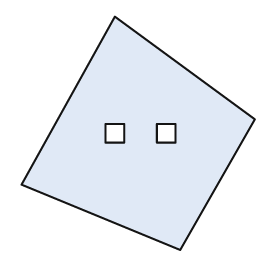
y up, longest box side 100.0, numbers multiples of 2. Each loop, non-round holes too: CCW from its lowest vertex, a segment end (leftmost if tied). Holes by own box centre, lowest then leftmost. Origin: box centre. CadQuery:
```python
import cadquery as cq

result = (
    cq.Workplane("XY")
    .moveTo(18.0, -50.0)
    .lineTo(50.0, 6.0)
    .lineTo(-10.0, 50.0)
    .lineTo(-50.0, -22.0)
    .close()
    .moveTo(-14.0, -4.0)
    .lineTo(-6.0, -4.0)
    .lineTo(-6.0, 4.0)
    .lineTo(-14.0, 4.0)
    .close()
    .moveTo(8.0, -4.0)
    .lineTo(16.0, -4.0)
    .lineTo(16.0, 4.0)
    .lineTo(8.0, 4.0)
    .close()
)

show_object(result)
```